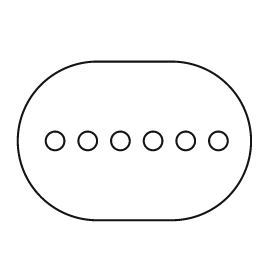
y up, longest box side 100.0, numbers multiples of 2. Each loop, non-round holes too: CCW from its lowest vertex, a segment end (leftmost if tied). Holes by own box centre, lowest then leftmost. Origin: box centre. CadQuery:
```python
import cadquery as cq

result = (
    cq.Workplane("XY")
    .moveTo(-16.0, -34.0)
    .lineTo(16.0, -34.0)
    .threePointArc((50.0, 0.0), (16.0, 34.0))
    .lineTo(-16.0, 34.0)
    .threePointArc((-50.0, 0.0), (-16.0, -34.0))
    .close()
    .moveTo(-34.0, 0.0)
    .circle(4.0)
    .moveTo(-20.0, 0.0)
    .circle(4.0)
    .moveTo(-6.0, 0.0)
    .circle(4.0)
    .moveTo(8.0, 0.0)
    .circle(4.0)
    .moveTo(22.0, 0.0)
    .circle(4.0)
    .moveTo(36.0, 0.0)
    .circle(4.0)
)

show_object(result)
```